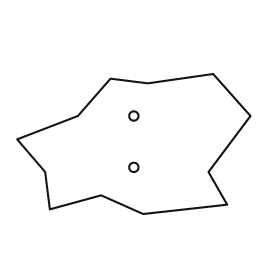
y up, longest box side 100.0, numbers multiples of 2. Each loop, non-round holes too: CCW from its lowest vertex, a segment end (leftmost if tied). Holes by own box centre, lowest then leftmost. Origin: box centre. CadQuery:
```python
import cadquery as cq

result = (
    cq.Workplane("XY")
    .moveTo(4.0, -30.0)
    .lineTo(40.0, -26.0)
    .lineTo(32.0, -12.0)
    .lineTo(50.0, 12.0)
    .lineTo(34.0, 30.0)
    .lineTo(6.0, 26.0)
    .lineTo(-10.0, 28.0)
    .lineTo(-24.0, 12.0)
    .lineTo(-50.0, 2.0)
    .lineTo(-38.0, -12.0)
    .lineTo(-36.0, -28.0)
    .lineTo(-14.0, -22.0)
    .close()
    .moveTo(0.0, -10.0)
    .circle(2.0)
    .moveTo(0.0, 12.0)
    .circle(2.0)
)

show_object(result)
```